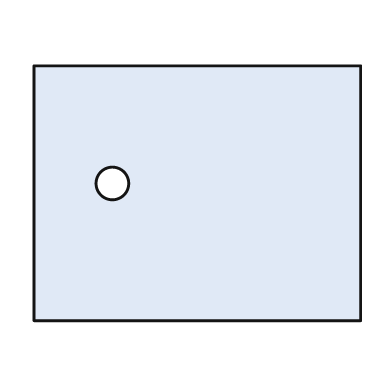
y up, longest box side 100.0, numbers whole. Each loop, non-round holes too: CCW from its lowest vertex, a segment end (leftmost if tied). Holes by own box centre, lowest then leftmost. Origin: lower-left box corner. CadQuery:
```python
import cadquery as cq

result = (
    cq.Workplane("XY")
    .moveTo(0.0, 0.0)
    .lineTo(100.0, 0.0)
    .lineTo(100.0, 78.0)
    .lineTo(0.0, 78.0)
    .close()
    .moveTo(24.0, 42.0)
    .circle(5.0)
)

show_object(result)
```